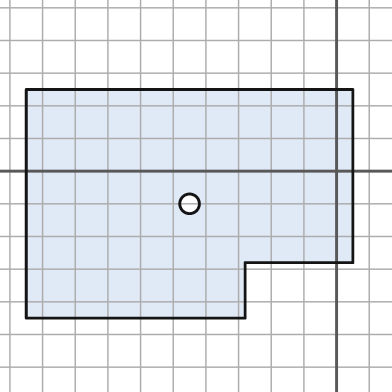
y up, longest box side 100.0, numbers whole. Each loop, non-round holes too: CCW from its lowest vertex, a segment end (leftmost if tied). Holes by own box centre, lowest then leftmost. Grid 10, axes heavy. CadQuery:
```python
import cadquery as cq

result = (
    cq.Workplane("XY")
    .moveTo(-95.0, -45.0)
    .lineTo(-28.0, -45.0)
    .lineTo(-28.0, -28.0)
    .lineTo(5.0, -28.0)
    .lineTo(5.0, 25.0)
    .lineTo(-95.0, 25.0)
    .close()
    .moveTo(-45.0, -10.0)
    .circle(3.0)
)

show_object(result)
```